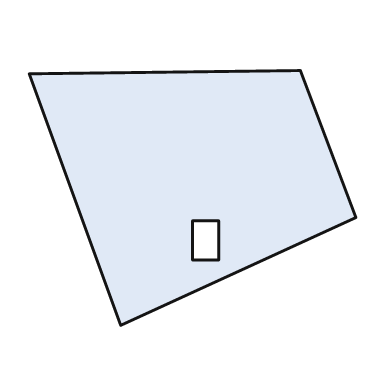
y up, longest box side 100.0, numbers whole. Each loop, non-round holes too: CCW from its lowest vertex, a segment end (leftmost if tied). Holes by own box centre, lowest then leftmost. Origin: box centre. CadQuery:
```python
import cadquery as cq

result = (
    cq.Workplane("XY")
    .moveTo(-22.0, -39.0)
    .lineTo(50.0, -6.0)
    .lineTo(33.0, 39.0)
    .lineTo(-50.0, 38.0)
    .close()
    .moveTo(0.0, -19.0)
    .lineTo(8.0, -19.0)
    .lineTo(8.0, -7.0)
    .lineTo(0.0, -7.0)
    .close()
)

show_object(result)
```